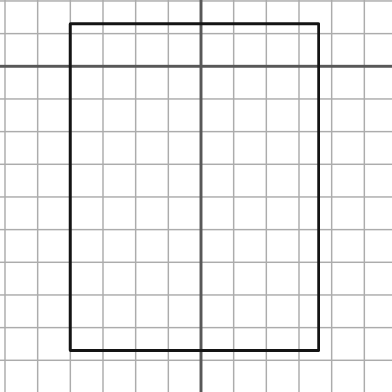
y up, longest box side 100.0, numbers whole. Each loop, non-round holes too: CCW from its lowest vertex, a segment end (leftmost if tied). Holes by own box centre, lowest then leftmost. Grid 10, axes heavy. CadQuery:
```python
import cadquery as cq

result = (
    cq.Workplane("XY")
    .moveTo(-40.0, -87.0)
    .lineTo(36.0, -87.0)
    .lineTo(36.0, 13.0)
    .lineTo(-40.0, 13.0)
    .close()
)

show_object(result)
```